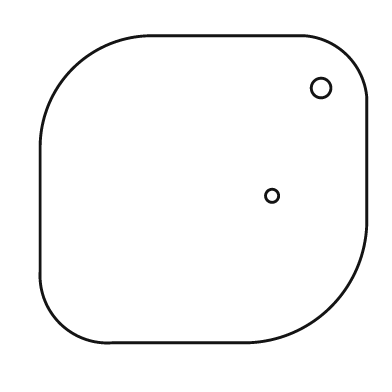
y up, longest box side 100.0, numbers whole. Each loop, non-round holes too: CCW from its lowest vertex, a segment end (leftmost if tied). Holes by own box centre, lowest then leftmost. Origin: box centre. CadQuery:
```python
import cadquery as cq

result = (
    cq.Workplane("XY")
    .moveTo(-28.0, -47.0)
    .lineTo(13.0, -47.0)
    .threePointArc((39.0, -36.0), (50.0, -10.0))
    .lineTo(50.0, 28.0)
    .threePointArc((44.0, 41.0), (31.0, 47.0))
    .lineTo(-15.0, 47.0)
    .threePointArc((-40.0, 37.0), (-50.0, 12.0))
    .lineTo(-50.0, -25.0)
    .threePointArc((-44.0, -41.0), (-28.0, -47.0))
    .close()
    .moveTo(21.0, -2.0)
    .circle(2.0)
    .moveTo(36.0, 31.0)
    .circle(3.0)
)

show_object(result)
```